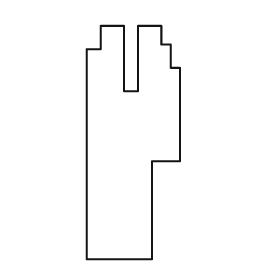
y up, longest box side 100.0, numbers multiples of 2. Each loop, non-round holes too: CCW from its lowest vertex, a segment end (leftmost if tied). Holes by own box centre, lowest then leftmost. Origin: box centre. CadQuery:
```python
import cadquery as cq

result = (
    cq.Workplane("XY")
    .moveTo(-20.0, -50.0)
    .lineTo(8.0, -50.0)
    .lineTo(8.0, -8.0)
    .lineTo(20.0, -8.0)
    .lineTo(20.0, 32.0)
    .lineTo(16.0, 32.0)
    .lineTo(16.0, 42.0)
    .lineTo(12.0, 42.0)
    .lineTo(12.0, 50.0)
    .lineTo(2.0, 50.0)
    .lineTo(2.0, 22.0)
    .lineTo(-4.0, 22.0)
    .lineTo(-4.0, 50.0)
    .lineTo(-14.0, 50.0)
    .lineTo(-14.0, 40.0)
    .lineTo(-20.0, 40.0)
    .close()
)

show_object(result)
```